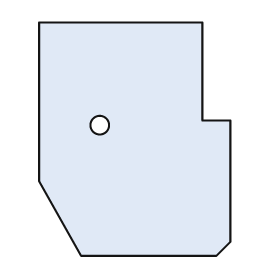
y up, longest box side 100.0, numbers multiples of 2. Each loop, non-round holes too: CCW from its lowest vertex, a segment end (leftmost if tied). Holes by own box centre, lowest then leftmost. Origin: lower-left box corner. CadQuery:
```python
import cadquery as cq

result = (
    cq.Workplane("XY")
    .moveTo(18.0, 0.0)
    .lineTo(76.0, 0.0)
    .lineTo(82.0, 6.0)
    .lineTo(82.0, 58.0)
    .lineTo(70.0, 58.0)
    .lineTo(70.0, 100.0)
    .lineTo(0.0, 100.0)
    .lineTo(0.0, 32.0)
    .close()
    .moveTo(26.0, 56.0)
    .circle(4.0)
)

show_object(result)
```